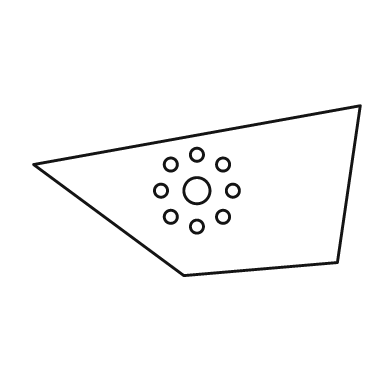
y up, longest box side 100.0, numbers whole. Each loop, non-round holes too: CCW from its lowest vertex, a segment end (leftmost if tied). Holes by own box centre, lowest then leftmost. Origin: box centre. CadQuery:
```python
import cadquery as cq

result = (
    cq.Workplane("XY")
    .moveTo(-4.0, -26.0)
    .lineTo(43.0, -22.0)
    .lineTo(50.0, 26.0)
    .lineTo(-50.0, 8.0)
    .close()
    .moveTo(0.0, -11.0)
    .circle(2.0)
    .moveTo(-8.0, -8.0)
    .circle(2.0)
    .moveTo(8.0, -8.0)
    .circle(2.0)
    .moveTo(-11.0, 0.0)
    .circle(2.0)
    .moveTo(0.0, 0.0)
    .circle(4.0)
    .moveTo(11.0, 0.0)
    .circle(2.0)
    .moveTo(-8.0, 8.0)
    .circle(2.0)
    .moveTo(8.0, 8.0)
    .circle(2.0)
    .moveTo(0.0, 11.0)
    .circle(2.0)
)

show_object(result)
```